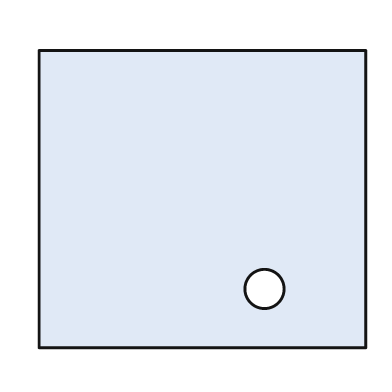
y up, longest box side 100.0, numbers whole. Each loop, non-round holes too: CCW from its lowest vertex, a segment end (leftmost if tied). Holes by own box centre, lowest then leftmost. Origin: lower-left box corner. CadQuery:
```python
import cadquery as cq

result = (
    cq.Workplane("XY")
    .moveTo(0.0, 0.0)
    .lineTo(100.0, 0.0)
    .lineTo(100.0, 91.0)
    .lineTo(0.0, 91.0)
    .close()
    .moveTo(69.0, 18.0)
    .circle(6.0)
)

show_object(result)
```